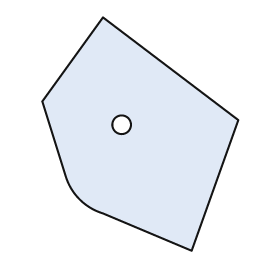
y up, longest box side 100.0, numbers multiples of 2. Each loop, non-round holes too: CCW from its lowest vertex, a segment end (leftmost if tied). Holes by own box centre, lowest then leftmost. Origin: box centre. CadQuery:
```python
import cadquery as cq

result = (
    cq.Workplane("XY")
    .moveTo(22.0, -50.0)
    .lineTo(42.0, 6.0)
    .lineTo(-16.0, 50.0)
    .lineTo(-42.0, 14.0)
    .lineTo(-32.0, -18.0)
    .threePointArc((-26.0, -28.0), (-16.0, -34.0))
    .close()
    .moveTo(-8.0, 4.0)
    .circle(4.0)
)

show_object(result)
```